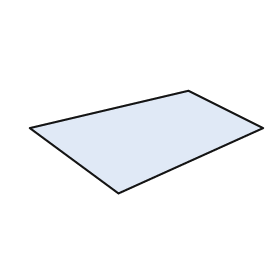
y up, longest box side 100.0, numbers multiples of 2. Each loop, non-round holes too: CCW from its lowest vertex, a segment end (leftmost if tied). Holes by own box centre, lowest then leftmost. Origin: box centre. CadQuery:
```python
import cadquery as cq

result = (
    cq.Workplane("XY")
    .moveTo(-12.0, -22.0)
    .lineTo(50.0, 6.0)
    .lineTo(18.0, 22.0)
    .lineTo(-50.0, 6.0)
    .close()
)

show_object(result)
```